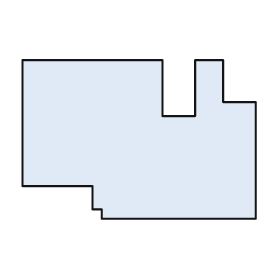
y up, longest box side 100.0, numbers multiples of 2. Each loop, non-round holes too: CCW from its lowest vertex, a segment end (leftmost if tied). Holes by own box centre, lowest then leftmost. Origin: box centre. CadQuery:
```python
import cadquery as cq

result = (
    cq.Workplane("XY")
    .moveTo(-16.0, -34.0)
    .lineTo(50.0, -34.0)
    .lineTo(50.0, 16.0)
    .lineTo(36.0, 16.0)
    .lineTo(36.0, 34.0)
    .lineTo(24.0, 34.0)
    .lineTo(24.0, 10.0)
    .lineTo(10.0, 10.0)
    .lineTo(10.0, 34.0)
    .lineTo(-50.0, 34.0)
    .lineTo(-50.0, -20.0)
    .lineTo(-20.0, -20.0)
    .lineTo(-20.0, -30.0)
    .lineTo(-16.0, -30.0)
    .close()
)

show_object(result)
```